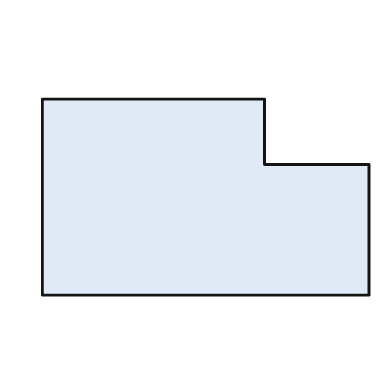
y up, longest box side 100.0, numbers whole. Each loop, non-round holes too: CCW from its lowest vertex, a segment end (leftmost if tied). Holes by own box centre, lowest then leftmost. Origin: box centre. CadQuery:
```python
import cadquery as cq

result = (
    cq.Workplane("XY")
    .moveTo(-50.0, -30.0)
    .lineTo(50.0, -30.0)
    .lineTo(50.0, 10.0)
    .lineTo(18.0, 10.0)
    .lineTo(18.0, 30.0)
    .lineTo(-50.0, 30.0)
    .close()
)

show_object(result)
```